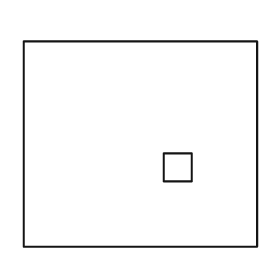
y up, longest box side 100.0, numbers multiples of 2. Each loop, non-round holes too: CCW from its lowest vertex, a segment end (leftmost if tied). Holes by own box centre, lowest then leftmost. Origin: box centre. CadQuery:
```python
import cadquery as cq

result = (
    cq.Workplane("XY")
    .moveTo(-50.0, -44.0)
    .lineTo(50.0, -44.0)
    .lineTo(50.0, 44.0)
    .lineTo(-50.0, 44.0)
    .close()
    .moveTo(10.0, -16.0)
    .lineTo(22.0, -16.0)
    .lineTo(22.0, -4.0)
    .lineTo(10.0, -4.0)
    .close()
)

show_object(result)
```